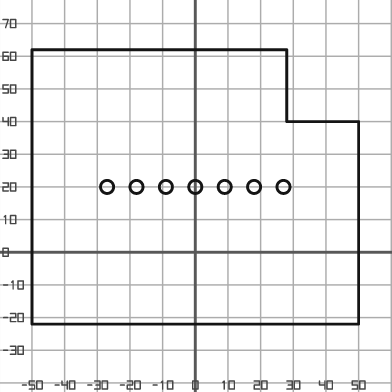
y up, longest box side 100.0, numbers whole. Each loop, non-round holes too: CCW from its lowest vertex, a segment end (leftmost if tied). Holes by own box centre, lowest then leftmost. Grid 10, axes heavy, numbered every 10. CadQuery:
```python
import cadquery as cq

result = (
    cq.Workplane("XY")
    .moveTo(-50.0, -22.0)
    .lineTo(50.0, -22.0)
    .lineTo(50.0, 40.0)
    .lineTo(28.0, 40.0)
    .lineTo(28.0, 62.0)
    .lineTo(-50.0, 62.0)
    .close()
    .moveTo(-27.0, 20.0)
    .circle(2.0)
    .moveTo(-18.0, 20.0)
    .circle(2.0)
    .moveTo(-9.0, 20.0)
    .circle(2.0)
    .moveTo(0.0, 20.0)
    .circle(2.0)
    .moveTo(9.0, 20.0)
    .circle(2.0)
    .moveTo(18.0, 20.0)
    .circle(2.0)
    .moveTo(27.0, 20.0)
    .circle(2.0)
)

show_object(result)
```